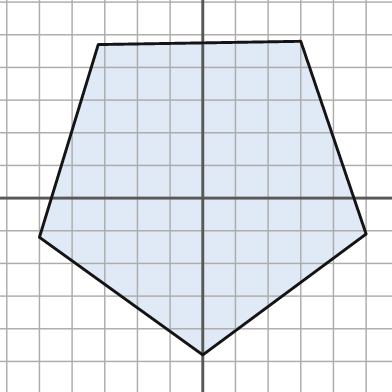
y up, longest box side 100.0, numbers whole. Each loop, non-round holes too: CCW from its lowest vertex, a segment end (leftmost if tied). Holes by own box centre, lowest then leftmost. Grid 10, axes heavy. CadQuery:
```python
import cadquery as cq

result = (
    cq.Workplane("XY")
    .moveTo(0.0, -48.0)
    .lineTo(50.0, -11.0)
    .lineTo(30.0, 48.0)
    .lineTo(-32.0, 47.0)
    .lineTo(-50.0, -12.0)
    .close()
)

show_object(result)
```